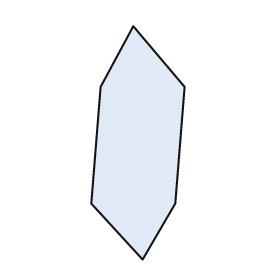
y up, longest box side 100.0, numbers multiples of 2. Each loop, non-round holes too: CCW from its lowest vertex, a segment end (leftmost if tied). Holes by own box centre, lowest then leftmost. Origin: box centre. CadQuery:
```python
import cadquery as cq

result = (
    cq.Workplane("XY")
    .moveTo(2.0, -50.0)
    .lineTo(16.0, -26.0)
    .lineTo(20.0, 24.0)
    .lineTo(-2.0, 50.0)
    .lineTo(-16.0, 24.0)
    .lineTo(-20.0, -26.0)
    .close()
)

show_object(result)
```